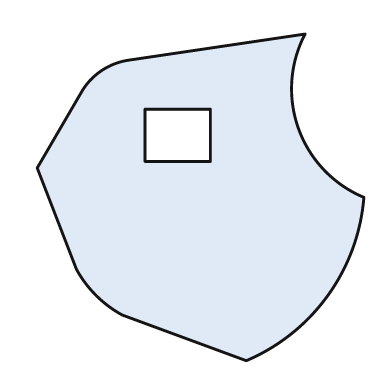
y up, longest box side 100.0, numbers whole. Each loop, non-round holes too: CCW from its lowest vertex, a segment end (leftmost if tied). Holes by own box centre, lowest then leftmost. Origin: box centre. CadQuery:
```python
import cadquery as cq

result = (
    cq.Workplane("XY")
    .moveTo(14.0, -50.0)
    .threePointArc((39.0, -30.0), (50.0, 0.0))
    .threePointArc((30.0, 21.0), (32.0, 50.0))
    .lineTo(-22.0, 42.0)
    .threePointArc((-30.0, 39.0), (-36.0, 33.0))
    .lineTo(-50.0, 9.0)
    .lineTo(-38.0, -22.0)
    .threePointArc((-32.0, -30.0), (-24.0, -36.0))
    .close()
    .moveTo(-17.0, 11.0)
    .lineTo(3.0, 11.0)
    .lineTo(3.0, 27.0)
    .lineTo(-17.0, 27.0)
    .close()
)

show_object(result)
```